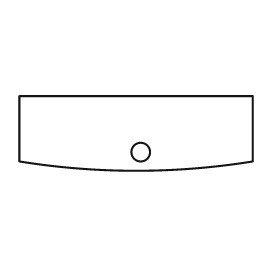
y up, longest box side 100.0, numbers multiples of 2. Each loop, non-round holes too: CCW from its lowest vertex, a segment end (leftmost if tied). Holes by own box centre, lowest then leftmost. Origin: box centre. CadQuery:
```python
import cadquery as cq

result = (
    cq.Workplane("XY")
    .moveTo(-50.0, -12.0)
    .threePointArc((0.0, -16.0), (50.0, -12.0))
    .lineTo(50.0, 16.0)
    .lineTo(-50.0, 16.0)
    .close()
    .moveTo(2.0, -8.0)
    .circle(4.0)
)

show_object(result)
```